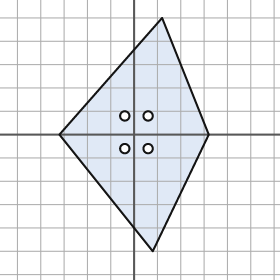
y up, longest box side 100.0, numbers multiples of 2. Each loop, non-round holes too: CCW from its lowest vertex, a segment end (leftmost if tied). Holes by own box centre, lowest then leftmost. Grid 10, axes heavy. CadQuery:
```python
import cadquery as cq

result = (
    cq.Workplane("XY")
    .moveTo(8.0, -50.0)
    .lineTo(32.0, 0.0)
    .lineTo(12.0, 50.0)
    .lineTo(-32.0, 0.0)
    .close()
    .moveTo(-4.0, -6.0)
    .circle(2.0)
    .moveTo(6.0, -6.0)
    .circle(2.0)
    .moveTo(-4.0, 8.0)
    .circle(2.0)
    .moveTo(6.0, 8.0)
    .circle(2.0)
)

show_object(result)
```